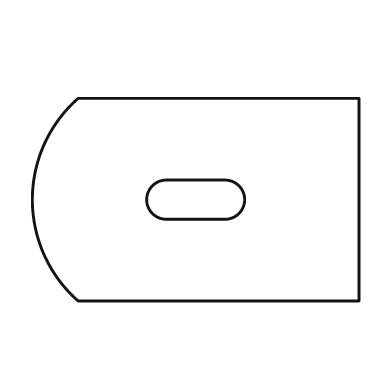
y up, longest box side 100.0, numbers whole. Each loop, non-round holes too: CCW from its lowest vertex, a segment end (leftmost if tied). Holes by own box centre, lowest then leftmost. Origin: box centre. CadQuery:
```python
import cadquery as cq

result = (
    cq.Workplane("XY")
    .moveTo(-36.0, -31.0)
    .lineTo(50.0, -31.0)
    .lineTo(50.0, 31.0)
    .lineTo(-36.0, 31.0)
    .threePointArc((-50.0, 0.0), (-36.0, -31.0))
    .close()
    .moveTo(-9.0, -6.0)
    .lineTo(9.0, -6.0)
    .threePointArc((15.0, 0.0), (9.0, 6.0))
    .lineTo(-9.0, 6.0)
    .threePointArc((-15.0, 0.0), (-9.0, -6.0))
    .close()
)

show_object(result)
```